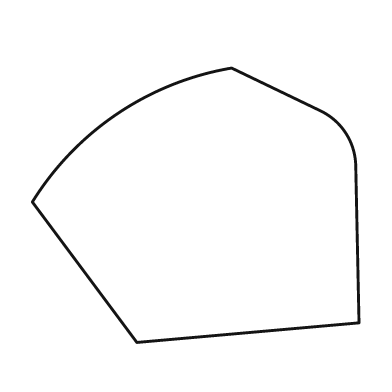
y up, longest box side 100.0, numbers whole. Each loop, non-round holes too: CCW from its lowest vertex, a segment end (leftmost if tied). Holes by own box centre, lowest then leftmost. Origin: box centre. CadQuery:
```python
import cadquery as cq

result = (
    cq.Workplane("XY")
    .moveTo(-18.0, -42.0)
    .lineTo(50.0, -36.0)
    .lineTo(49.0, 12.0)
    .threePointArc((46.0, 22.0), (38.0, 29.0))
    .lineTo(11.0, 42.0)
    .threePointArc((-24.0, 28.0), (-50.0, 1.0))
    .close()
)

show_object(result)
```